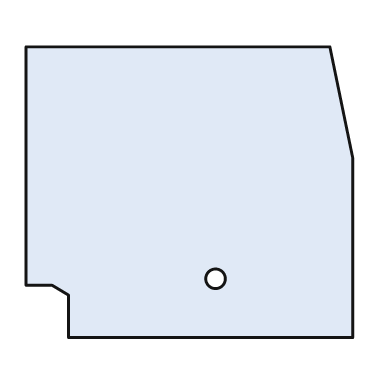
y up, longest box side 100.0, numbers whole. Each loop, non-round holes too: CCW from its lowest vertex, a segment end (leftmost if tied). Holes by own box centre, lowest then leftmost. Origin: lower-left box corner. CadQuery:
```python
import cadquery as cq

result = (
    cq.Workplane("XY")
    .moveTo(13.0, 0.0)
    .lineTo(100.0, 0.0)
    .lineTo(100.0, 55.0)
    .lineTo(93.0, 89.0)
    .lineTo(0.0, 89.0)
    .lineTo(0.0, 16.0)
    .lineTo(8.0, 16.0)
    .lineTo(13.0, 13.0)
    .close()
    .moveTo(58.0, 18.0)
    .circle(3.0)
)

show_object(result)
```